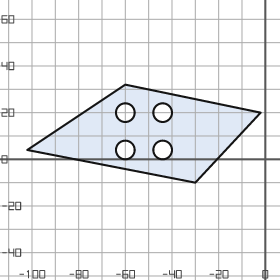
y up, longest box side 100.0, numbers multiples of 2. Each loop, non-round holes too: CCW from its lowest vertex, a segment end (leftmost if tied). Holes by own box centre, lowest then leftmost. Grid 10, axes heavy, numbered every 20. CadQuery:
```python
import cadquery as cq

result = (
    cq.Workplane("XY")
    .moveTo(-30.0, -10.0)
    .lineTo(-2.0, 20.0)
    .lineTo(-60.0, 32.0)
    .lineTo(-102.0, 4.0)
    .close()
    .moveTo(-60.0, 4.0)
    .circle(4.0)
    .moveTo(-44.0, 4.0)
    .circle(4.0)
    .moveTo(-60.0, 20.0)
    .circle(4.0)
    .moveTo(-44.0, 20.0)
    .circle(4.0)
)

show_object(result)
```